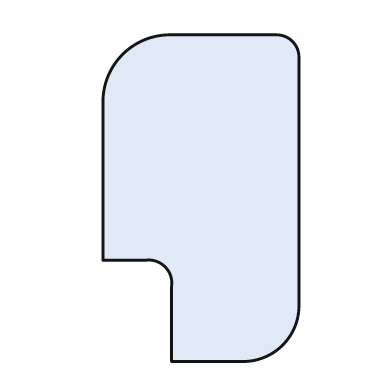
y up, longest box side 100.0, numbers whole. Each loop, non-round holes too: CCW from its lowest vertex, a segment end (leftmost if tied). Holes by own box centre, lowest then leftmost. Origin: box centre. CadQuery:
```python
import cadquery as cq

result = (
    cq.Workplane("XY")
    .moveTo(-9.0, -50.0)
    .lineTo(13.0, -50.0)
    .threePointArc((25.0, -45.0), (30.0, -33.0))
    .lineTo(30.0, 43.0)
    .threePointArc((28.0, 48.0), (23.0, 50.0))
    .lineTo(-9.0, 50.0)
    .threePointArc((-24.0, 44.0), (-30.0, 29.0))
    .lineTo(-30.0, -19.0)
    .lineTo(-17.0, -19.0)
    .threePointArc((-11.0, -21.0), (-9.0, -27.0))
    .close()
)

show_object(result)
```